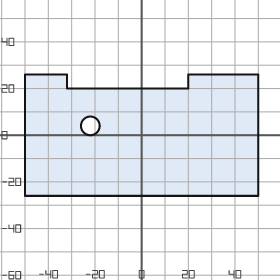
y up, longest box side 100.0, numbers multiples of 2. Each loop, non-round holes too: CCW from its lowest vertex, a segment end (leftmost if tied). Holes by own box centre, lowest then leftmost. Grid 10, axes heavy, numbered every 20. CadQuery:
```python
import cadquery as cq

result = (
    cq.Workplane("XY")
    .moveTo(-50.0, -26.0)
    .lineTo(50.0, -26.0)
    .lineTo(50.0, 26.0)
    .lineTo(20.0, 26.0)
    .lineTo(20.0, 20.0)
    .lineTo(-32.0, 20.0)
    .lineTo(-32.0, 26.0)
    .lineTo(-50.0, 26.0)
    .close()
    .moveTo(-22.0, 4.0)
    .circle(4.0)
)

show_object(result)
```